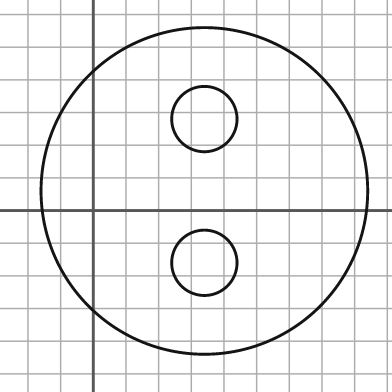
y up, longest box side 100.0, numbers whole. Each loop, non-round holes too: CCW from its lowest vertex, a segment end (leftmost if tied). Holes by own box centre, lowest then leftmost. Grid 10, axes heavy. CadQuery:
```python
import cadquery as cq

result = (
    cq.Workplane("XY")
    .moveTo(34.0, 6.0)
    .circle(50.0)
    .moveTo(34.0, -16.0)
    .circle(10.0)
    .moveTo(34.0, 28.0)
    .circle(10.0)
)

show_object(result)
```